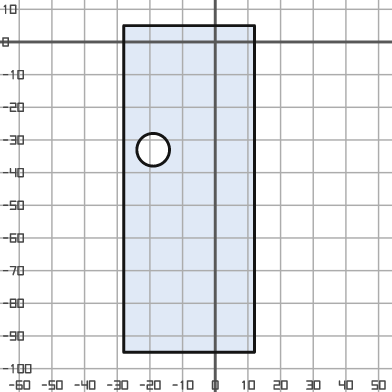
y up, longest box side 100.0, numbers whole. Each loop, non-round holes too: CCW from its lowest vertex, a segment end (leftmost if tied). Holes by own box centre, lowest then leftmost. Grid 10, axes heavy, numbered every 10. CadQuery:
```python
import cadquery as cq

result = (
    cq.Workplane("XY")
    .moveTo(-28.0, -95.0)
    .lineTo(12.0, -95.0)
    .lineTo(12.0, 5.0)
    .lineTo(-28.0, 5.0)
    .close()
    .moveTo(-19.0, -33.0)
    .circle(5.0)
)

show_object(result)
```